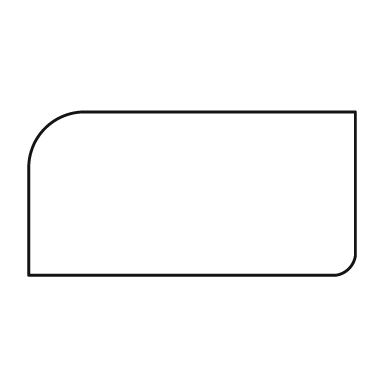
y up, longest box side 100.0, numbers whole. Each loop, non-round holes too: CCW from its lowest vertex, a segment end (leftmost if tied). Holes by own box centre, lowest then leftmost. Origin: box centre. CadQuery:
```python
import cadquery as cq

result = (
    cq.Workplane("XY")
    .moveTo(-50.0, -25.0)
    .lineTo(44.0, -25.0)
    .threePointArc((48.0, -23.0), (50.0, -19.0))
    .lineTo(50.0, 25.0)
    .lineTo(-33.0, 25.0)
    .threePointArc((-45.0, 20.0), (-50.0, 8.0))
    .close()
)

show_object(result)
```